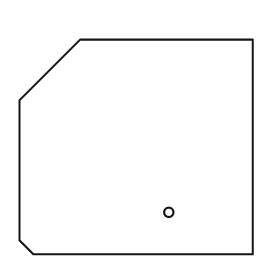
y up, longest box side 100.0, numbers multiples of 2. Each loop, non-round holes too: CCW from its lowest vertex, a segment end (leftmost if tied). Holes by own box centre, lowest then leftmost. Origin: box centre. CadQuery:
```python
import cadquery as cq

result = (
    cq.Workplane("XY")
    .moveTo(-44.0, -46.0)
    .lineTo(50.0, -46.0)
    .lineTo(50.0, 46.0)
    .lineTo(-24.0, 46.0)
    .lineTo(-50.0, 20.0)
    .lineTo(-50.0, -40.0)
    .close()
    .moveTo(14.0, -28.0)
    .circle(2.0)
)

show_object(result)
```